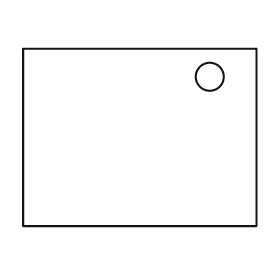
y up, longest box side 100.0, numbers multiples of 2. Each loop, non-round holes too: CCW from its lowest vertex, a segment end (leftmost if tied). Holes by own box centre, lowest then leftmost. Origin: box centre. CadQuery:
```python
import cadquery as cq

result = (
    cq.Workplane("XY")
    .moveTo(-50.0, -38.0)
    .lineTo(50.0, -38.0)
    .lineTo(50.0, 38.0)
    .lineTo(-50.0, 38.0)
    .close()
    .moveTo(30.0, 26.0)
    .circle(6.0)
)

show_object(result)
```